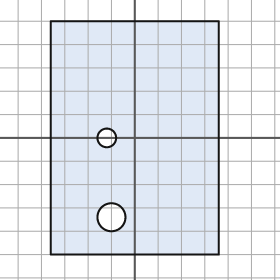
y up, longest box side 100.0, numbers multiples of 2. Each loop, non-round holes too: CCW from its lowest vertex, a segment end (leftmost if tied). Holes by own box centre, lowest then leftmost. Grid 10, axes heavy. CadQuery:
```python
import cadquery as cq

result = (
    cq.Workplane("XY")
    .moveTo(-36.0, -50.0)
    .lineTo(36.0, -50.0)
    .lineTo(36.0, 50.0)
    .lineTo(-36.0, 50.0)
    .close()
    .moveTo(-10.0, -34.0)
    .circle(6.0)
    .moveTo(-12.0, 0.0)
    .circle(4.0)
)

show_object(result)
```